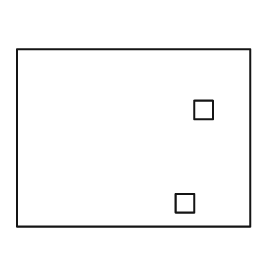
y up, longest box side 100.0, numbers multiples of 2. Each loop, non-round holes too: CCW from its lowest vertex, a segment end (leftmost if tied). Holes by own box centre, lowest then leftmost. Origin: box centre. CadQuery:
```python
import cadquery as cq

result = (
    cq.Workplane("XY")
    .moveTo(-50.0, -38.0)
    .lineTo(50.0, -38.0)
    .lineTo(50.0, 38.0)
    .lineTo(-50.0, 38.0)
    .close()
    .moveTo(18.0, -32.0)
    .lineTo(26.0, -32.0)
    .lineTo(26.0, -24.0)
    .lineTo(18.0, -24.0)
    .close()
    .moveTo(26.0, 8.0)
    .lineTo(34.0, 8.0)
    .lineTo(34.0, 16.0)
    .lineTo(26.0, 16.0)
    .close()
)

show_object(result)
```